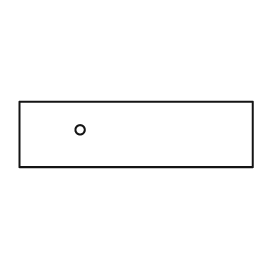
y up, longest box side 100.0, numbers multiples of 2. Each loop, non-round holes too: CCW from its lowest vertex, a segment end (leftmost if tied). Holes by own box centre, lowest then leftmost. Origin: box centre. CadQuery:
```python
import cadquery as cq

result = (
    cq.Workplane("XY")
    .moveTo(-50.0, -14.0)
    .lineTo(50.0, -14.0)
    .lineTo(50.0, 14.0)
    .lineTo(-50.0, 14.0)
    .close()
    .moveTo(-24.0, 2.0)
    .circle(2.0)
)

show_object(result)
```